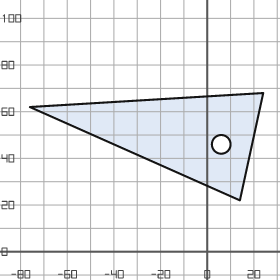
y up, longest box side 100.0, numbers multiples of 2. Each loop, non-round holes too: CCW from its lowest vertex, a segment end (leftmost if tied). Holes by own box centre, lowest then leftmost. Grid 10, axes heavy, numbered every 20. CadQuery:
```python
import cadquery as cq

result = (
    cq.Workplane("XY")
    .moveTo(14.0, 22.0)
    .lineTo(24.0, 68.0)
    .lineTo(-76.0, 62.0)
    .close()
    .moveTo(6.0, 46.0)
    .circle(4.0)
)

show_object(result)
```